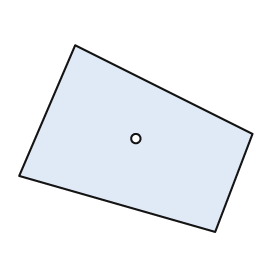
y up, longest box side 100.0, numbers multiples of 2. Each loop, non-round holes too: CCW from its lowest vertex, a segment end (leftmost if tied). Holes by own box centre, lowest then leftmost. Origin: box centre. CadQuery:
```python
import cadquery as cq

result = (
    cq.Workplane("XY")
    .moveTo(34.0, -40.0)
    .lineTo(50.0, 2.0)
    .lineTo(-26.0, 40.0)
    .lineTo(-50.0, -16.0)
    .close()
    .moveTo(0.0, 0.0)
    .circle(2.0)
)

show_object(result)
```